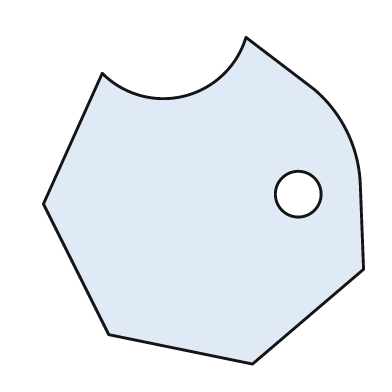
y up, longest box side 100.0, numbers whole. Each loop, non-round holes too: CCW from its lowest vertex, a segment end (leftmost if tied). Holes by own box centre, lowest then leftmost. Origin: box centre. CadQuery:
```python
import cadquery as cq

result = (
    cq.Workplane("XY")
    .moveTo(15.0, -50.0)
    .lineTo(49.0, -21.0)
    .lineTo(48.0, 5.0)
    .threePointArc((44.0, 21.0), (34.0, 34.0))
    .lineTo(13.0, 50.0)
    .threePointArc((-6.0, 32.0), (-31.0, 39.0))
    .lineTo(-49.0, -1.0)
    .lineTo(-29.0, -41.0)
    .close()
    .moveTo(29.0, 2.0)
    .circle(7.0)
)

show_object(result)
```